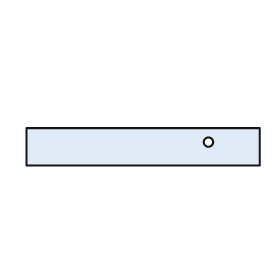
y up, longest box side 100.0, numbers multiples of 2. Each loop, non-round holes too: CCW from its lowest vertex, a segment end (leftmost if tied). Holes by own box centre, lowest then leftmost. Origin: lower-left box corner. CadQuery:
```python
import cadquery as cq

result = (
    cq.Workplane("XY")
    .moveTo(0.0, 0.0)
    .lineTo(100.0, 0.0)
    .lineTo(100.0, 16.0)
    .lineTo(0.0, 16.0)
    .close()
    .moveTo(78.0, 10.0)
    .circle(2.0)
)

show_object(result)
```